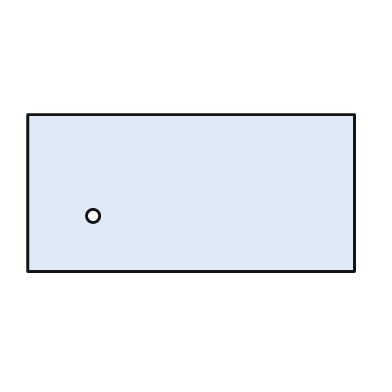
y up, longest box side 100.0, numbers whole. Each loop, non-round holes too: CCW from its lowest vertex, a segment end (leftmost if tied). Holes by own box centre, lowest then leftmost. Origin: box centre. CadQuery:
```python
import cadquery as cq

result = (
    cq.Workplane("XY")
    .moveTo(-50.0, -24.0)
    .lineTo(50.0, -24.0)
    .lineTo(50.0, 24.0)
    .lineTo(-50.0, 24.0)
    .close()
    .moveTo(-30.0, -7.0)
    .circle(2.0)
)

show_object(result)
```